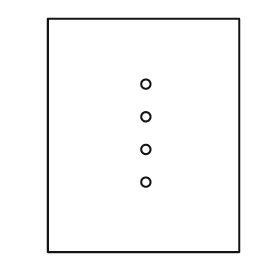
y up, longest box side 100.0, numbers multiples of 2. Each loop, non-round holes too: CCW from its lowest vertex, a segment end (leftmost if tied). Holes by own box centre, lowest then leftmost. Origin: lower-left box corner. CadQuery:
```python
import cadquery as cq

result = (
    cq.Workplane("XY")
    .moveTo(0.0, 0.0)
    .lineTo(82.0, 0.0)
    .lineTo(82.0, 100.0)
    .lineTo(0.0, 100.0)
    .close()
    .moveTo(42.0, 30.0)
    .circle(2.0)
    .moveTo(42.0, 44.0)
    .circle(2.0)
    .moveTo(42.0, 58.0)
    .circle(2.0)
    .moveTo(42.0, 72.0)
    .circle(2.0)
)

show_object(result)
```